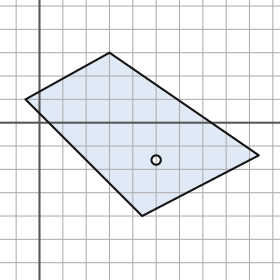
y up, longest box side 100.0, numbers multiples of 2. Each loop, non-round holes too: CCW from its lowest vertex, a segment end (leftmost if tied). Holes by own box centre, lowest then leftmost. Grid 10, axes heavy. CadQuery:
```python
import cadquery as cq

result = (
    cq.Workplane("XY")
    .moveTo(44.0, -40.0)
    .lineTo(94.0, -14.0)
    .lineTo(30.0, 30.0)
    .lineTo(-6.0, 10.0)
    .close()
    .moveTo(50.0, -16.0)
    .circle(2.0)
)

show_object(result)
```